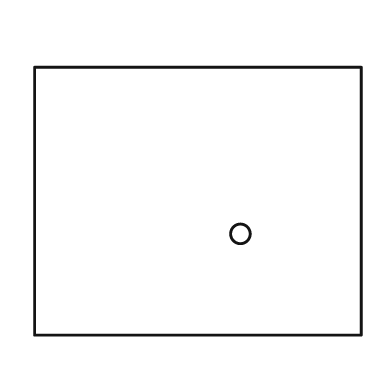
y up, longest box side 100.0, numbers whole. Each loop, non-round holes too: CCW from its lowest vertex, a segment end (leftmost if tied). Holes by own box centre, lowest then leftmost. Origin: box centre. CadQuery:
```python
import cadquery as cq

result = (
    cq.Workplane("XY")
    .moveTo(-50.0, -41.0)
    .lineTo(50.0, -41.0)
    .lineTo(50.0, 41.0)
    .lineTo(-50.0, 41.0)
    .close()
    .moveTo(13.0, -10.0)
    .circle(3.0)
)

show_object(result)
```